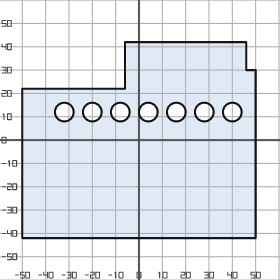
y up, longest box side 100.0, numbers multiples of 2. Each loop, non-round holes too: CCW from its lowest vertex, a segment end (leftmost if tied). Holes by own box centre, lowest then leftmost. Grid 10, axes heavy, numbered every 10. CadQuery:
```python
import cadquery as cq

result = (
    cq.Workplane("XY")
    .moveTo(-50.0, -42.0)
    .lineTo(50.0, -42.0)
    .lineTo(50.0, 30.0)
    .lineTo(46.0, 30.0)
    .lineTo(46.0, 42.0)
    .lineTo(-6.0, 42.0)
    .lineTo(-6.0, 22.0)
    .lineTo(-50.0, 22.0)
    .close()
    .moveTo(-32.0, 12.0)
    .circle(4.0)
    .moveTo(-20.0, 12.0)
    .circle(4.0)
    .moveTo(-8.0, 12.0)
    .circle(4.0)
    .moveTo(4.0, 12.0)
    .circle(4.0)
    .moveTo(16.0, 12.0)
    .circle(4.0)
    .moveTo(28.0, 12.0)
    .circle(4.0)
    .moveTo(40.0, 12.0)
    .circle(4.0)
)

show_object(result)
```